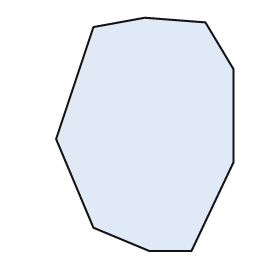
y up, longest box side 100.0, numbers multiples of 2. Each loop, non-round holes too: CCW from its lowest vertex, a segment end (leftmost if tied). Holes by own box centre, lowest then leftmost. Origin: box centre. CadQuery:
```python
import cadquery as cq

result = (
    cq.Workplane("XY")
    .moveTo(2.0, -50.0)
    .lineTo(20.0, -50.0)
    .lineTo(38.0, -12.0)
    .lineTo(38.0, 28.0)
    .lineTo(26.0, 48.0)
    .lineTo(0.0, 50.0)
    .lineTo(-22.0, 46.0)
    .lineTo(-38.0, -2.0)
    .lineTo(-22.0, -40.0)
    .close()
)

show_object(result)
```